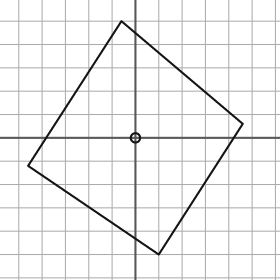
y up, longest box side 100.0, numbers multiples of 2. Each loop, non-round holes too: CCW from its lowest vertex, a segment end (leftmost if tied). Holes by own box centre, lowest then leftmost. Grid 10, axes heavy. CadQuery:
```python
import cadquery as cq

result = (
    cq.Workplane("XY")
    .moveTo(10.0, -50.0)
    .lineTo(46.0, 6.0)
    .lineTo(-6.0, 50.0)
    .lineTo(-46.0, -12.0)
    .close()
    .moveTo(0.0, 0.0)
    .circle(2.0)
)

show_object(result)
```